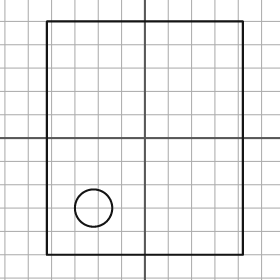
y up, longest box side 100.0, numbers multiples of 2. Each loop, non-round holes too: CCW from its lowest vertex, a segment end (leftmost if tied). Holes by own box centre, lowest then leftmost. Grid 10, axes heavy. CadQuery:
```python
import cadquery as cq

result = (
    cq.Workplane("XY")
    .moveTo(-42.0, -50.0)
    .lineTo(42.0, -50.0)
    .lineTo(42.0, 50.0)
    .lineTo(-42.0, 50.0)
    .close()
    .moveTo(-22.0, -30.0)
    .circle(8.0)
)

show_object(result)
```